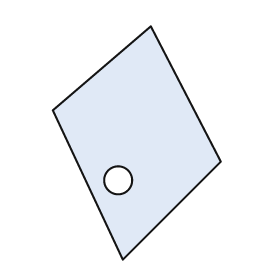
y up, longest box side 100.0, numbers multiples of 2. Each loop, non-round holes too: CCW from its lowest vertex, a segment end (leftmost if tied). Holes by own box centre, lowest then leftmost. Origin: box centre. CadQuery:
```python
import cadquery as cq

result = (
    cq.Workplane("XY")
    .moveTo(-6.0, -50.0)
    .lineTo(36.0, -8.0)
    .lineTo(6.0, 50.0)
    .lineTo(-36.0, 14.0)
    .close()
    .moveTo(-8.0, -16.0)
    .circle(6.0)
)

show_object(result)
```